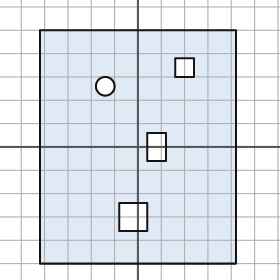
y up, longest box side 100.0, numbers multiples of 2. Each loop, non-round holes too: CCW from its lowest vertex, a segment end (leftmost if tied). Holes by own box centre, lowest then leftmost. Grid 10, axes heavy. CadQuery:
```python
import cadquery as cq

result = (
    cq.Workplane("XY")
    .moveTo(-42.0, -50.0)
    .lineTo(42.0, -50.0)
    .lineTo(42.0, 50.0)
    .lineTo(-42.0, 50.0)
    .close()
    .moveTo(-8.0, -36.0)
    .lineTo(4.0, -36.0)
    .lineTo(4.0, -24.0)
    .lineTo(-8.0, -24.0)
    .close()
    .moveTo(4.0, -6.0)
    .lineTo(12.0, -6.0)
    .lineTo(12.0, 6.0)
    .lineTo(4.0, 6.0)
    .close()
    .moveTo(-14.0, 26.0)
    .circle(4.0)
    .moveTo(16.0, 30.0)
    .lineTo(24.0, 30.0)
    .lineTo(24.0, 38.0)
    .lineTo(16.0, 38.0)
    .close()
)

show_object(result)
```